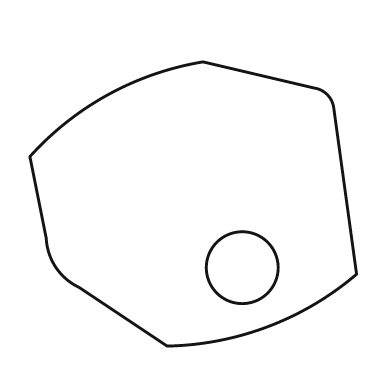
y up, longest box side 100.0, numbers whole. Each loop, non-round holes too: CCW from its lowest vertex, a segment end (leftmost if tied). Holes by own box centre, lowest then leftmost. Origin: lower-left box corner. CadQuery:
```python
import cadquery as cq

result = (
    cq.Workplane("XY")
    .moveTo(42.0, 0.0)
    .threePointArc((73.0, 6.0), (100.0, 22.0))
    .lineTo(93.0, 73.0)
    .threePointArc((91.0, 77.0), (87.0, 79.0))
    .lineTo(53.0, 87.0)
    .threePointArc((24.0, 77.0), (0.0, 58.0))
    .lineTo(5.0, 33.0)
    .threePointArc((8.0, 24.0), (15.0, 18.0))
    .close()
    .moveTo(65.0, 24.0)
    .circle(11.0)
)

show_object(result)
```